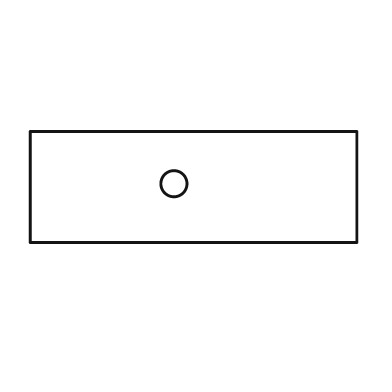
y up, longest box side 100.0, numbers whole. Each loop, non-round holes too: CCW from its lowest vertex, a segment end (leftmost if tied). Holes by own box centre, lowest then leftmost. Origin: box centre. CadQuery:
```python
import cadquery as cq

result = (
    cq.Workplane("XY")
    .moveTo(-50.0, -17.0)
    .lineTo(50.0, -17.0)
    .lineTo(50.0, 17.0)
    .lineTo(-50.0, 17.0)
    .close()
    .moveTo(-6.0, 1.0)
    .circle(4.0)
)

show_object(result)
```